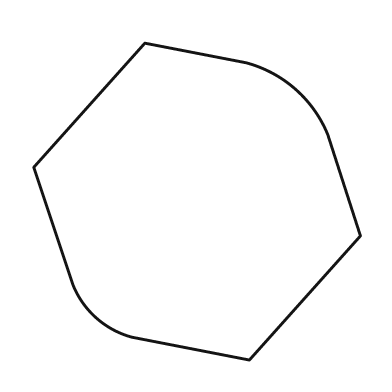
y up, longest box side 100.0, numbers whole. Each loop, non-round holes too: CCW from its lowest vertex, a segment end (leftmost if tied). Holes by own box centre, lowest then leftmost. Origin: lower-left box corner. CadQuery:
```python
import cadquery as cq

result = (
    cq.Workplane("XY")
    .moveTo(66.0, 0.0)
    .lineTo(100.0, 38.0)
    .lineTo(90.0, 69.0)
    .threePointArc((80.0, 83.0), (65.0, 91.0))
    .lineTo(34.0, 97.0)
    .lineTo(0.0, 59.0)
    .lineTo(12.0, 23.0)
    .threePointArc((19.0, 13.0), (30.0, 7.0))
    .close()
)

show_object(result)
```